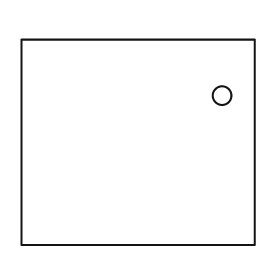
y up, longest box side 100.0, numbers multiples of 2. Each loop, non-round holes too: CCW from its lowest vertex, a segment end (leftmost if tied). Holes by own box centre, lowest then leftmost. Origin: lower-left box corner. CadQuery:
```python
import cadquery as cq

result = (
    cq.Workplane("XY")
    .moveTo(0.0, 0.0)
    .lineTo(100.0, 0.0)
    .lineTo(100.0, 88.0)
    .lineTo(0.0, 88.0)
    .close()
    .moveTo(86.0, 64.0)
    .circle(4.0)
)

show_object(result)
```